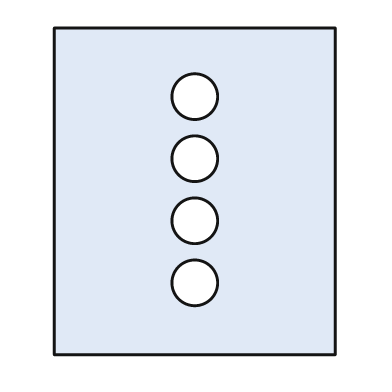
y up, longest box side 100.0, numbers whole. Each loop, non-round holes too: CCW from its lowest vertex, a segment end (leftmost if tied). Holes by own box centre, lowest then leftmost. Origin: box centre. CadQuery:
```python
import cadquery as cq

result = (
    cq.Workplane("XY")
    .moveTo(-43.0, -50.0)
    .lineTo(43.0, -50.0)
    .lineTo(43.0, 50.0)
    .lineTo(-43.0, 50.0)
    .close()
    .moveTo(0.0, -28.0)
    .circle(7.0)
    .moveTo(0.0, -9.0)
    .circle(7.0)
    .moveTo(0.0, 10.0)
    .circle(7.0)
    .moveTo(0.0, 29.0)
    .circle(7.0)
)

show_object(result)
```